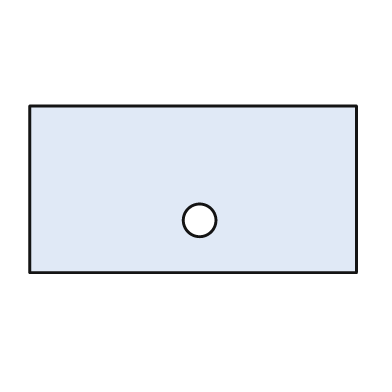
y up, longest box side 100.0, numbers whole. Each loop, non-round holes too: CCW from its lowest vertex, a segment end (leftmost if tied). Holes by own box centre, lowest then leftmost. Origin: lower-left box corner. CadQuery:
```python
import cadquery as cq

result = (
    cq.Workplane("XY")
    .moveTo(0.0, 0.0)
    .lineTo(100.0, 0.0)
    .lineTo(100.0, 51.0)
    .lineTo(0.0, 51.0)
    .close()
    .moveTo(52.0, 16.0)
    .circle(5.0)
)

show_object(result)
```